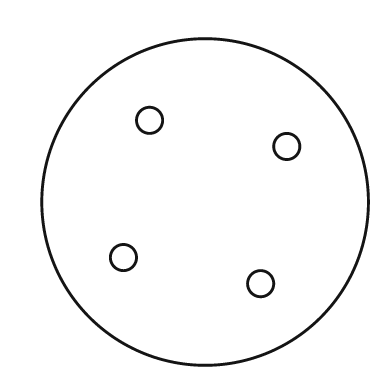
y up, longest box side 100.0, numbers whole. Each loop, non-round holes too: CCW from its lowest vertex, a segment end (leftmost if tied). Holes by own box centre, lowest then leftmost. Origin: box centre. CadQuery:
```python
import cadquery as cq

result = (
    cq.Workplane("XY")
    .moveTo(0.0, 0.0)
    .circle(50.0)
    .moveTo(17.0, -25.0)
    .circle(4.0)
    .moveTo(-25.0, -17.0)
    .circle(4.0)
    .moveTo(25.0, 17.0)
    .circle(4.0)
    .moveTo(-17.0, 25.0)
    .circle(4.0)
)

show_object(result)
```